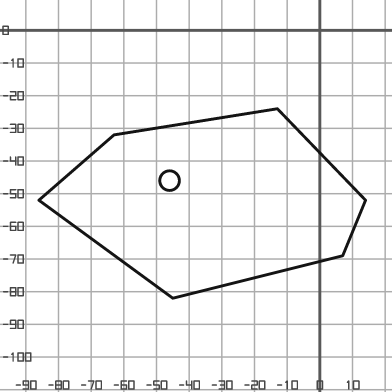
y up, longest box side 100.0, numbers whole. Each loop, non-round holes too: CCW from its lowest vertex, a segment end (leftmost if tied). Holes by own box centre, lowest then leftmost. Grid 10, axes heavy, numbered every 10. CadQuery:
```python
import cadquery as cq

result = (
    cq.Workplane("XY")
    .moveTo(-45.0, -82.0)
    .lineTo(7.0, -69.0)
    .lineTo(14.0, -52.0)
    .lineTo(-13.0, -24.0)
    .lineTo(-63.0, -32.0)
    .lineTo(-86.0, -52.0)
    .close()
    .moveTo(-46.0, -46.0)
    .circle(3.0)
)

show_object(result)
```